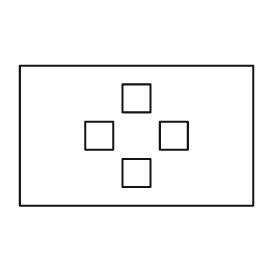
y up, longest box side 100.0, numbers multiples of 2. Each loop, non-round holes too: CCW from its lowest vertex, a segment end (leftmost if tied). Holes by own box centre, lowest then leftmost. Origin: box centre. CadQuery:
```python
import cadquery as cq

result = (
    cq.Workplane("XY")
    .moveTo(-50.0, -30.0)
    .lineTo(50.0, -30.0)
    .lineTo(50.0, 30.0)
    .lineTo(-50.0, 30.0)
    .close()
    .moveTo(-6.0, -22.0)
    .lineTo(6.0, -22.0)
    .lineTo(6.0, -10.0)
    .lineTo(-6.0, -10.0)
    .close()
    .moveTo(-22.0, -6.0)
    .lineTo(-10.0, -6.0)
    .lineTo(-10.0, 6.0)
    .lineTo(-22.0, 6.0)
    .close()
    .moveTo(10.0, -6.0)
    .lineTo(22.0, -6.0)
    .lineTo(22.0, 6.0)
    .lineTo(10.0, 6.0)
    .close()
    .moveTo(-6.0, 10.0)
    .lineTo(6.0, 10.0)
    .lineTo(6.0, 22.0)
    .lineTo(-6.0, 22.0)
    .close()
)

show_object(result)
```